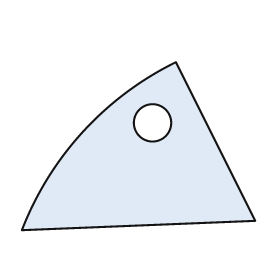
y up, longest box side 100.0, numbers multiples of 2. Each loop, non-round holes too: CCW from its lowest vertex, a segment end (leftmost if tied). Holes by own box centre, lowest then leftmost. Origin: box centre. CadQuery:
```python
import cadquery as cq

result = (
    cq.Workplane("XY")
    .moveTo(-50.0, -36.0)
    .lineTo(50.0, -32.0)
    .lineTo(16.0, 36.0)
    .threePointArc((-24.0, 6.0), (-50.0, -36.0))
    .close()
    .moveTo(6.0, 10.0)
    .circle(8.0)
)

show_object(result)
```